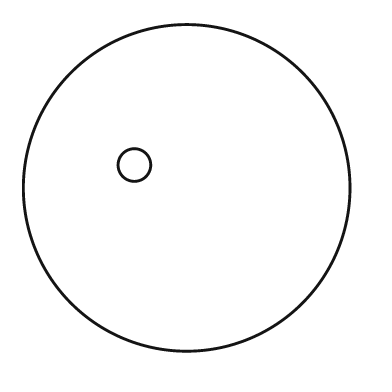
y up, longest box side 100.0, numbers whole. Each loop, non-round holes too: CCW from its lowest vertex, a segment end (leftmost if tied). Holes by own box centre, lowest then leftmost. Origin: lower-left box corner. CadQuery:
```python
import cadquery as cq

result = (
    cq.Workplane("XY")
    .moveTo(50.0, 50.0)
    .circle(50.0)
    .moveTo(34.0, 57.0)
    .circle(5.0)
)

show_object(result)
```